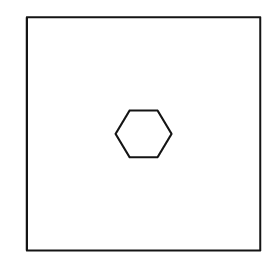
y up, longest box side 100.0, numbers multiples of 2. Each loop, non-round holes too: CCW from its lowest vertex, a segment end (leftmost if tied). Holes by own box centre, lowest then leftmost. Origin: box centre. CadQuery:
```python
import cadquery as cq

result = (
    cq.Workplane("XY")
    .moveTo(-50.0, -50.0)
    .lineTo(50.0, -50.0)
    .lineTo(50.0, 50.0)
    .lineTo(-50.0, 50.0)
    .close()
    .moveTo(-6.0, -10.0)
    .lineTo(6.0, -10.0)
    .lineTo(12.0, 0.0)
    .lineTo(6.0, 10.0)
    .lineTo(-6.0, 10.0)
    .lineTo(-12.0, 0.0)
    .close()
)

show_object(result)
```